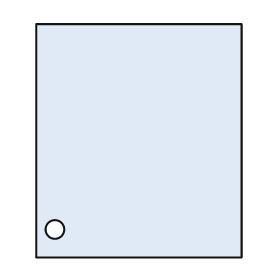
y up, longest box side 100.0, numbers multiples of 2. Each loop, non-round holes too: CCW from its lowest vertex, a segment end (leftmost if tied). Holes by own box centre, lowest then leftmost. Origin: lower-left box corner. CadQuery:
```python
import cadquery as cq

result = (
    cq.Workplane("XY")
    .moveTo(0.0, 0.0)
    .lineTo(88.0, 0.0)
    .lineTo(88.0, 100.0)
    .lineTo(0.0, 100.0)
    .close()
    .moveTo(8.0, 12.0)
    .circle(4.0)
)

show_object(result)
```